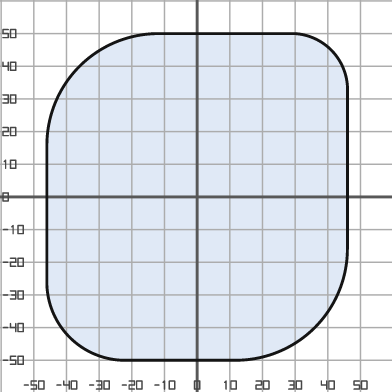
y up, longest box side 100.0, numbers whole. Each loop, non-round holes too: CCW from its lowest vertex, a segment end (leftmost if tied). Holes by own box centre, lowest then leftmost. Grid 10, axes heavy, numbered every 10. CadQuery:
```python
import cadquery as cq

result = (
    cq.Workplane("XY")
    .moveTo(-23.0, -50.0)
    .lineTo(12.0, -50.0)
    .threePointArc((36.0, -40.0), (46.0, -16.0))
    .lineTo(46.0, 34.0)
    .threePointArc((41.0, 45.0), (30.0, 50.0))
    .lineTo(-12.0, 50.0)
    .threePointArc((-36.0, 40.0), (-46.0, 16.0))
    .lineTo(-46.0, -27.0)
    .threePointArc((-39.0, -43.0), (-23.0, -50.0))
    .close()
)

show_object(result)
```